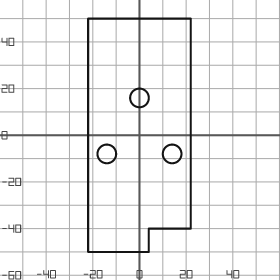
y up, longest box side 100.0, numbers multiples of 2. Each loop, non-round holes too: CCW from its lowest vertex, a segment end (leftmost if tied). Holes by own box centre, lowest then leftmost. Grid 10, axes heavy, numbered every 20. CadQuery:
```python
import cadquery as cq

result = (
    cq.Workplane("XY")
    .moveTo(-22.0, -50.0)
    .lineTo(4.0, -50.0)
    .lineTo(4.0, -40.0)
    .lineTo(22.0, -40.0)
    .lineTo(22.0, 50.0)
    .lineTo(-22.0, 50.0)
    .close()
    .moveTo(-14.0, -8.0)
    .circle(4.0)
    .moveTo(14.0, -8.0)
    .circle(4.0)
    .moveTo(0.0, 16.0)
    .circle(4.0)
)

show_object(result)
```